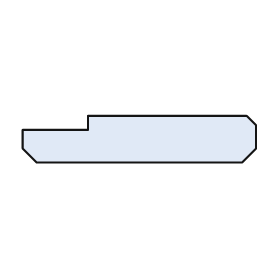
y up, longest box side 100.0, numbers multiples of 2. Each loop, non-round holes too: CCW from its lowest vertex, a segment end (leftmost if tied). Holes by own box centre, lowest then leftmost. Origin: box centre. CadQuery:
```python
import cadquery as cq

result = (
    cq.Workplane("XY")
    .moveTo(-44.0, -10.0)
    .lineTo(44.0, -10.0)
    .lineTo(50.0, -4.0)
    .lineTo(50.0, 6.0)
    .lineTo(46.0, 10.0)
    .lineTo(-22.0, 10.0)
    .lineTo(-22.0, 4.0)
    .lineTo(-50.0, 4.0)
    .lineTo(-50.0, -4.0)
    .close()
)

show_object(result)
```